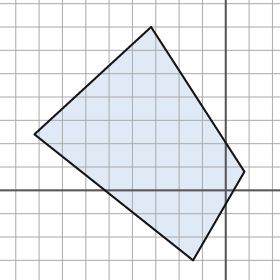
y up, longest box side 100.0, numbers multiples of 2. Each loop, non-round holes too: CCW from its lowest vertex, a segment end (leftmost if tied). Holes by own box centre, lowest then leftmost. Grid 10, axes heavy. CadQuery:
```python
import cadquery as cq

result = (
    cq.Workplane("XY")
    .moveTo(-14.0, -30.0)
    .lineTo(8.0, 8.0)
    .lineTo(-32.0, 70.0)
    .lineTo(-82.0, 24.0)
    .close()
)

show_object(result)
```